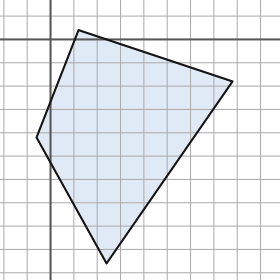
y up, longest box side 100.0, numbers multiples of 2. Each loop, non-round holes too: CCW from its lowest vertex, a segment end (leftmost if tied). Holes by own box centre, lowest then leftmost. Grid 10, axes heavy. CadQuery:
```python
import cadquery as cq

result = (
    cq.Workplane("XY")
    .moveTo(24.0, -96.0)
    .lineTo(78.0, -18.0)
    .lineTo(12.0, 4.0)
    .lineTo(-6.0, -42.0)
    .close()
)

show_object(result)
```